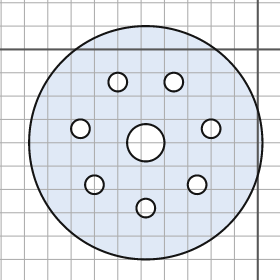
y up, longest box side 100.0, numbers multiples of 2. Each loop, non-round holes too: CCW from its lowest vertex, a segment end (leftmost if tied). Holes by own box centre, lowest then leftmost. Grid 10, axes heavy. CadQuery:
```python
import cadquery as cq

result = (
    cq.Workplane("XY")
    .moveTo(-48.0, -40.0)
    .circle(50.0)
    .moveTo(-48.0, -68.0)
    .circle(4.0)
    .moveTo(-70.0, -58.0)
    .circle(4.0)
    .moveTo(-26.0, -58.0)
    .circle(4.0)
    .moveTo(-48.0, -40.0)
    .circle(8.0)
    .moveTo(-76.0, -34.0)
    .circle(4.0)
    .moveTo(-20.0, -34.0)
    .circle(4.0)
    .moveTo(-60.0, -14.0)
    .circle(4.0)
    .moveTo(-36.0, -14.0)
    .circle(4.0)
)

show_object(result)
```